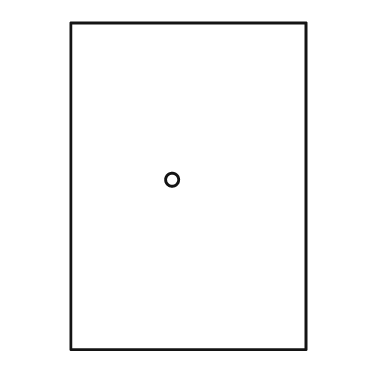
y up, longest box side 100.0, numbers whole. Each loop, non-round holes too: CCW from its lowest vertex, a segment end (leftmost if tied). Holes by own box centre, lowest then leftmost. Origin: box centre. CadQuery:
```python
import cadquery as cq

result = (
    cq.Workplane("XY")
    .moveTo(-36.0, -50.0)
    .lineTo(36.0, -50.0)
    .lineTo(36.0, 50.0)
    .lineTo(-36.0, 50.0)
    .close()
    .moveTo(-5.0, 2.0)
    .circle(2.0)
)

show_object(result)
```